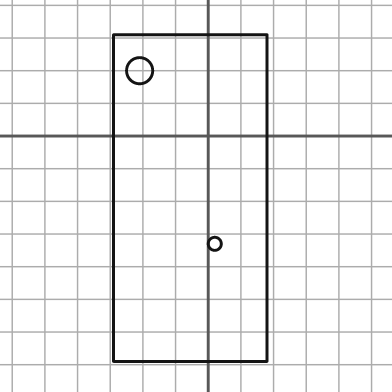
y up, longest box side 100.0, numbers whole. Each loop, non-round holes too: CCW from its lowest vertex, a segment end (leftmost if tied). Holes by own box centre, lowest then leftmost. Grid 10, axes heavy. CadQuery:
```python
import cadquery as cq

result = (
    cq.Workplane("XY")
    .moveTo(-29.0, -69.0)
    .lineTo(18.0, -69.0)
    .lineTo(18.0, 31.0)
    .lineTo(-29.0, 31.0)
    .close()
    .moveTo(2.0, -33.0)
    .circle(2.0)
    .moveTo(-21.0, 20.0)
    .circle(4.0)
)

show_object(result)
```